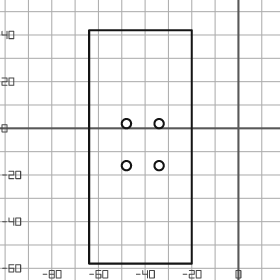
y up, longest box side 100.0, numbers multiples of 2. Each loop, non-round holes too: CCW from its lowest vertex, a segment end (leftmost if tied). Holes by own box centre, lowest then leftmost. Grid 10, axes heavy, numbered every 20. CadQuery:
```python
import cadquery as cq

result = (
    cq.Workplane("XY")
    .moveTo(-64.0, -58.0)
    .lineTo(-20.0, -58.0)
    .lineTo(-20.0, 42.0)
    .lineTo(-64.0, 42.0)
    .close()
    .moveTo(-48.0, -16.0)
    .circle(2.0)
    .moveTo(-34.0, -16.0)
    .circle(2.0)
    .moveTo(-48.0, 2.0)
    .circle(2.0)
    .moveTo(-34.0, 2.0)
    .circle(2.0)
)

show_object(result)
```